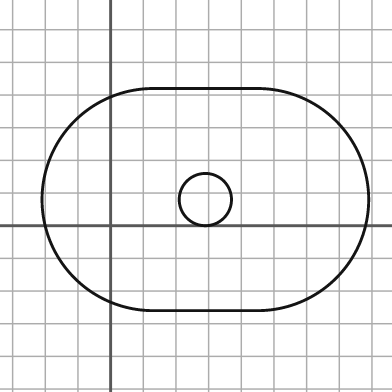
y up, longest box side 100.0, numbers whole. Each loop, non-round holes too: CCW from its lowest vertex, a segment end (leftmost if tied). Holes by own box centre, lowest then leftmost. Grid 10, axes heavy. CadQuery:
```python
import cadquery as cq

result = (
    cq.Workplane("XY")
    .moveTo(13.0, -26.0)
    .lineTo(45.0, -26.0)
    .threePointArc((79.0, 8.0), (45.0, 42.0))
    .lineTo(13.0, 42.0)
    .threePointArc((-21.0, 8.0), (13.0, -26.0))
    .close()
    .moveTo(29.0, 8.0)
    .circle(8.0)
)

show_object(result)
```